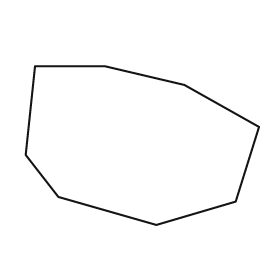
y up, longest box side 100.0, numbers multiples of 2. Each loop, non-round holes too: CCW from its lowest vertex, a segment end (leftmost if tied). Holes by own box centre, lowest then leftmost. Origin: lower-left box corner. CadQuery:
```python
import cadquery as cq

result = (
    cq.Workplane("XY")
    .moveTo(56.0, 0.0)
    .lineTo(90.0, 10.0)
    .lineTo(100.0, 42.0)
    .lineTo(68.0, 60.0)
    .lineTo(34.0, 68.0)
    .lineTo(4.0, 68.0)
    .lineTo(0.0, 30.0)
    .lineTo(14.0, 12.0)
    .close()
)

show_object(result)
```